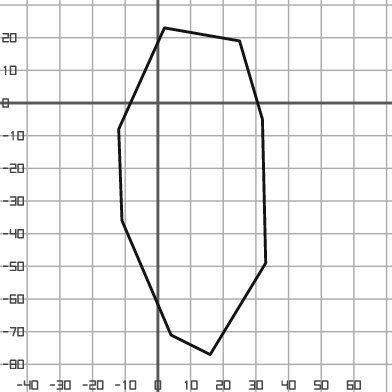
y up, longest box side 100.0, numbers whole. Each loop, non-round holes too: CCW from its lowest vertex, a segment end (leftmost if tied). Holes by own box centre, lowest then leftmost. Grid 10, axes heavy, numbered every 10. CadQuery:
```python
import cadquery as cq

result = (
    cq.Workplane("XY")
    .moveTo(16.0, -77.0)
    .lineTo(33.0, -49.0)
    .lineTo(32.0, -5.0)
    .lineTo(25.0, 19.0)
    .lineTo(2.0, 23.0)
    .lineTo(-12.0, -8.0)
    .lineTo(-11.0, -36.0)
    .lineTo(4.0, -71.0)
    .close()
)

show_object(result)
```